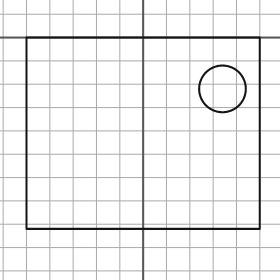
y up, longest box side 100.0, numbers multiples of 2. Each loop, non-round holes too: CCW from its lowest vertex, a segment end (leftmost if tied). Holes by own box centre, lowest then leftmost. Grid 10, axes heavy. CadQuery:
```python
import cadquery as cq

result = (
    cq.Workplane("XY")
    .moveTo(-50.0, -82.0)
    .lineTo(50.0, -82.0)
    .lineTo(50.0, 0.0)
    .lineTo(-50.0, 0.0)
    .close()
    .moveTo(34.0, -22.0)
    .circle(10.0)
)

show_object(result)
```